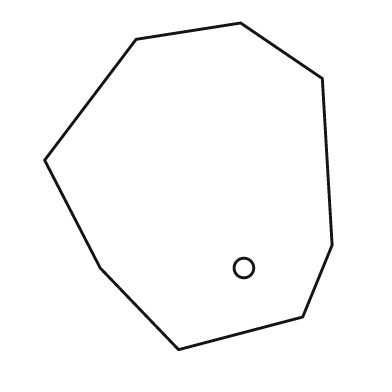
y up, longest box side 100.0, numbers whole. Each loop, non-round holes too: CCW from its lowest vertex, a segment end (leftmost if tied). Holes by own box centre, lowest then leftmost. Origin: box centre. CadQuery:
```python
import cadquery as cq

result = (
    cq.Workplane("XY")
    .moveTo(-3.0, -50.0)
    .lineTo(35.0, -40.0)
    .lineTo(44.0, -18.0)
    .lineTo(41.0, 33.0)
    .lineTo(16.0, 50.0)
    .lineTo(-16.0, 45.0)
    .lineTo(-44.0, 8.0)
    .lineTo(-27.0, -25.0)
    .close()
    .moveTo(17.0, -25.0)
    .circle(3.0)
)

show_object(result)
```